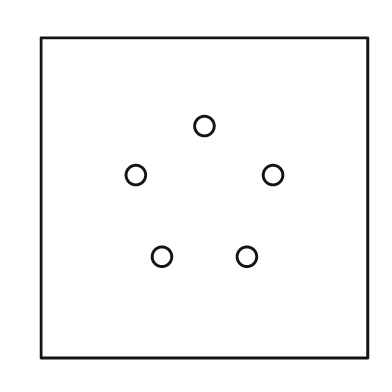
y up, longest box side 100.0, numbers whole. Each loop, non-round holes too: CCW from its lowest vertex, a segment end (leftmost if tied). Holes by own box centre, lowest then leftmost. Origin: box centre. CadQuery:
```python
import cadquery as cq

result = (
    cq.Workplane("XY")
    .moveTo(-50.0, -49.0)
    .lineTo(50.0, -49.0)
    .lineTo(50.0, 49.0)
    .lineTo(-50.0, 49.0)
    .close()
    .moveTo(-13.0, -18.0)
    .circle(3.0)
    .moveTo(13.0, -18.0)
    .circle(3.0)
    .moveTo(-21.0, 7.0)
    .circle(3.0)
    .moveTo(21.0, 7.0)
    .circle(3.0)
    .moveTo(0.0, 22.0)
    .circle(3.0)
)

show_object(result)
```